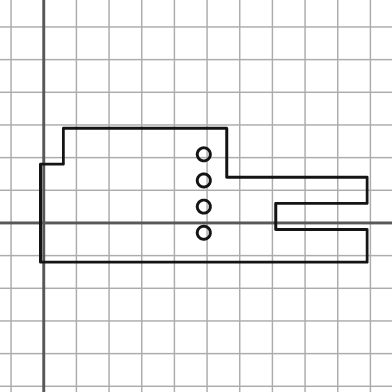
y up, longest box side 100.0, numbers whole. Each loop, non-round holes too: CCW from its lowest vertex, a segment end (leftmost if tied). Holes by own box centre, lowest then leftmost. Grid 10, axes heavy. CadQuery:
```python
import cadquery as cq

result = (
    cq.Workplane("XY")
    .moveTo(-1.0, -12.0)
    .lineTo(99.0, -12.0)
    .lineTo(99.0, -2.0)
    .lineTo(71.0, -2.0)
    .lineTo(71.0, 6.0)
    .lineTo(99.0, 6.0)
    .lineTo(99.0, 14.0)
    .lineTo(56.0, 14.0)
    .lineTo(56.0, 29.0)
    .lineTo(6.0, 29.0)
    .lineTo(6.0, 18.0)
    .lineTo(-1.0, 18.0)
    .close()
    .moveTo(49.0, -3.0)
    .circle(2.0)
    .moveTo(49.0, 5.0)
    .circle(2.0)
    .moveTo(49.0, 13.0)
    .circle(2.0)
    .moveTo(49.0, 21.0)
    .circle(2.0)
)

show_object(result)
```